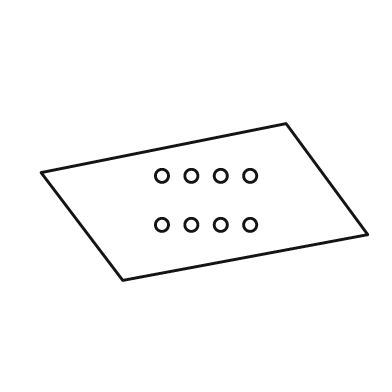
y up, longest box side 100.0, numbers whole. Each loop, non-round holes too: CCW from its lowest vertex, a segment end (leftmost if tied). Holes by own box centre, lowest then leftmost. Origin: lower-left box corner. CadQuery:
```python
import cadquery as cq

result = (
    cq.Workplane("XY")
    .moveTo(25.0, 0.0)
    .lineTo(100.0, 14.0)
    .lineTo(75.0, 48.0)
    .lineTo(0.0, 33.0)
    .close()
    .moveTo(37.0, 17.0)
    .circle(2.0)
    .moveTo(46.0, 17.0)
    .circle(2.0)
    .moveTo(55.0, 17.0)
    .circle(2.0)
    .moveTo(64.0, 17.0)
    .circle(2.0)
    .moveTo(37.0, 32.0)
    .circle(2.0)
    .moveTo(46.0, 32.0)
    .circle(2.0)
    .moveTo(55.0, 32.0)
    .circle(2.0)
    .moveTo(64.0, 32.0)
    .circle(2.0)
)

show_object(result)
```